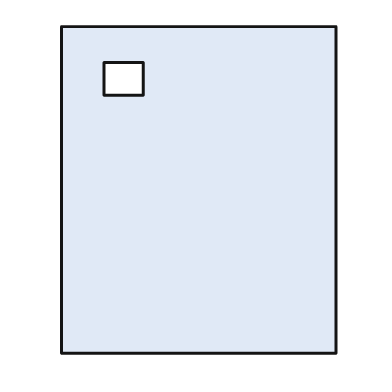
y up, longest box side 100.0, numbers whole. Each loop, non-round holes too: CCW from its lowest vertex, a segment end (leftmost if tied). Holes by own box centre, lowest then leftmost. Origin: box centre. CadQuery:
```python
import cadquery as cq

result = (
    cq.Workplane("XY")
    .moveTo(-42.0, -50.0)
    .lineTo(42.0, -50.0)
    .lineTo(42.0, 50.0)
    .lineTo(-42.0, 50.0)
    .close()
    .moveTo(-29.0, 29.0)
    .lineTo(-17.0, 29.0)
    .lineTo(-17.0, 39.0)
    .lineTo(-29.0, 39.0)
    .close()
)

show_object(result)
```